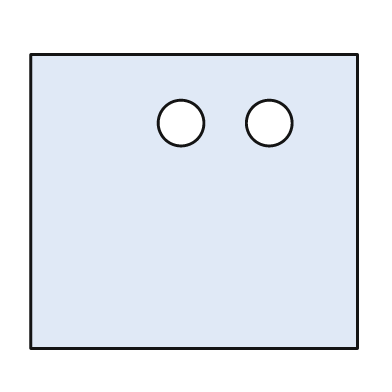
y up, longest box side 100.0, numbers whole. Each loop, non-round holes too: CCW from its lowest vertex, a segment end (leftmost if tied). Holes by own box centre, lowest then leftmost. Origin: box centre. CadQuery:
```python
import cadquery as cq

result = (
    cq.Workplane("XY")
    .moveTo(-50.0, -45.0)
    .lineTo(50.0, -45.0)
    .lineTo(50.0, 45.0)
    .lineTo(-50.0, 45.0)
    .close()
    .moveTo(-4.0, 24.0)
    .circle(7.0)
    .moveTo(23.0, 24.0)
    .circle(7.0)
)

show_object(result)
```